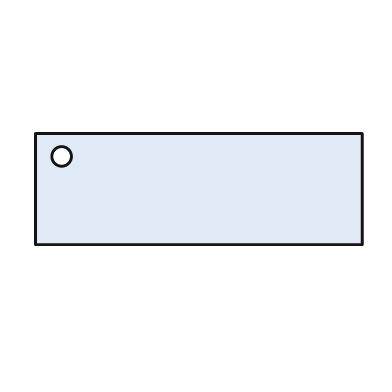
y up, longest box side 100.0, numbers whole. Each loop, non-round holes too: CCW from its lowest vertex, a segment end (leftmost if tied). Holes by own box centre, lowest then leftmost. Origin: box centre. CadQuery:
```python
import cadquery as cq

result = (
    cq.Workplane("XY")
    .moveTo(-50.0, -17.0)
    .lineTo(50.0, -17.0)
    .lineTo(50.0, 17.0)
    .lineTo(-50.0, 17.0)
    .close()
    .moveTo(-42.0, 10.0)
    .circle(3.0)
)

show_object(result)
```